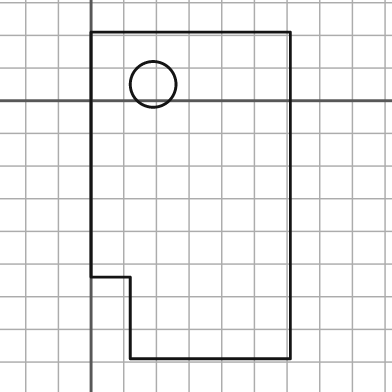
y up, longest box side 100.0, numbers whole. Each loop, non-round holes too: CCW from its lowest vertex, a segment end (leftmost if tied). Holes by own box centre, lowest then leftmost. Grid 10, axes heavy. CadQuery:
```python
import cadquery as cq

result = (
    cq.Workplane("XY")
    .moveTo(12.0, -79.0)
    .lineTo(61.0, -79.0)
    .lineTo(61.0, 21.0)
    .lineTo(0.0, 21.0)
    .lineTo(0.0, -54.0)
    .lineTo(12.0, -54.0)
    .close()
    .moveTo(19.0, 5.0)
    .circle(7.0)
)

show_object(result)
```